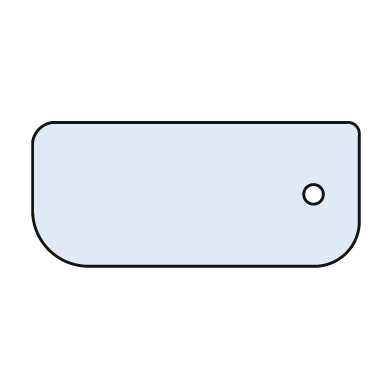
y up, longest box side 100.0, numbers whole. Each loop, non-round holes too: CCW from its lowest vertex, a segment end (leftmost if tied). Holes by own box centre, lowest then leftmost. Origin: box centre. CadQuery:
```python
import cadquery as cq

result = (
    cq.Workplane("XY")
    .moveTo(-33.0, -22.0)
    .lineTo(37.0, -22.0)
    .threePointArc((46.0, -18.0), (50.0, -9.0))
    .lineTo(50.0, 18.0)
    .threePointArc((49.0, 21.0), (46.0, 22.0))
    .lineTo(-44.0, 22.0)
    .threePointArc((-48.0, 20.0), (-50.0, 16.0))
    .lineTo(-50.0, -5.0)
    .threePointArc((-45.0, -17.0), (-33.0, -22.0))
    .close()
    .moveTo(36.0, 0.0)
    .circle(3.0)
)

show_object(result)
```